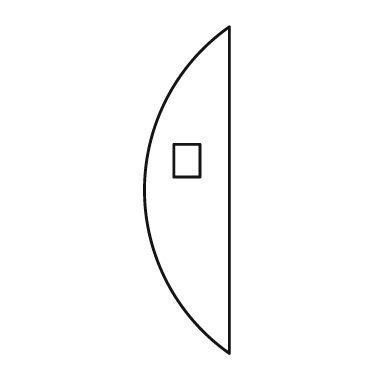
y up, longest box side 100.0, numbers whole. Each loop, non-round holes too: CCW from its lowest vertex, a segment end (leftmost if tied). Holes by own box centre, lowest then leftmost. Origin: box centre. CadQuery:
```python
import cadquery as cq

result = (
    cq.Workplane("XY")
    .moveTo(13.0, -50.0)
    .lineTo(13.0, 50.0)
    .threePointArc((-13.0, 0.0), (13.0, -50.0))
    .close()
    .moveTo(-4.0, 4.0)
    .lineTo(4.0, 4.0)
    .lineTo(4.0, 14.0)
    .lineTo(-4.0, 14.0)
    .close()
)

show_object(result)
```